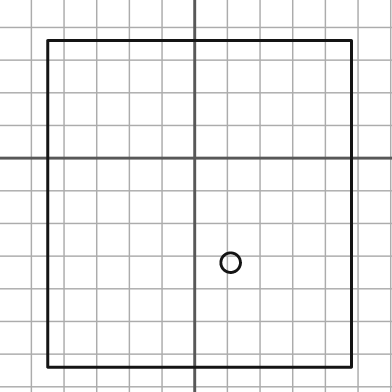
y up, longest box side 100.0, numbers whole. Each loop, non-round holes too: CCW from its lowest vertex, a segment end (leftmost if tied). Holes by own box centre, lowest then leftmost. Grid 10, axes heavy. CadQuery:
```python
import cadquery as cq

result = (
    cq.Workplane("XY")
    .moveTo(-45.0, -64.0)
    .lineTo(48.0, -64.0)
    .lineTo(48.0, 36.0)
    .lineTo(-45.0, 36.0)
    .close()
    .moveTo(11.0, -32.0)
    .circle(3.0)
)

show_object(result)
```